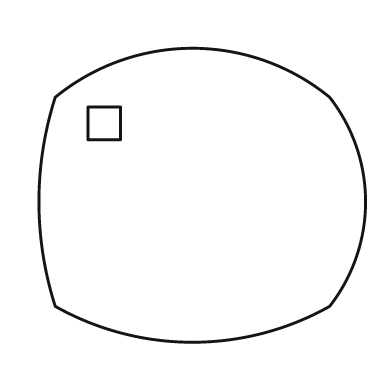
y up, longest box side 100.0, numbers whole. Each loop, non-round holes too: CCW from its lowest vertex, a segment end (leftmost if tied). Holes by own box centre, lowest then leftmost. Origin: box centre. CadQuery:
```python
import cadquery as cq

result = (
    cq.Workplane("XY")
    .moveTo(-45.0, -34.0)
    .threePointArc((-3.0, -45.0), (39.0, -34.0))
    .threePointArc((50.0, -2.0), (39.0, 30.0))
    .threePointArc((-3.0, 45.0), (-45.0, 30.0))
    .threePointArc((-50.0, -2.0), (-45.0, -34.0))
    .close()
    .moveTo(-35.0, 17.0)
    .lineTo(-25.0, 17.0)
    .lineTo(-25.0, 27.0)
    .lineTo(-35.0, 27.0)
    .close()
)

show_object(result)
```